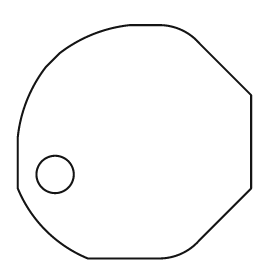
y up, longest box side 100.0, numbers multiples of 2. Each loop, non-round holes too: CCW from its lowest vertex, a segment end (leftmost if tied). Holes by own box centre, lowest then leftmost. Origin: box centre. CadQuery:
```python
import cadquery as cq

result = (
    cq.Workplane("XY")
    .moveTo(-20.0, -50.0)
    .lineTo(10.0, -50.0)
    .threePointArc((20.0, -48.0), (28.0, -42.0))
    .lineTo(50.0, -20.0)
    .lineTo(50.0, 20.0)
    .lineTo(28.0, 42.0)
    .threePointArc((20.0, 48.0), (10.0, 50.0))
    .lineTo(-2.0, 50.0)
    .threePointArc((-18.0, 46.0), (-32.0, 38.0))
    .lineTo(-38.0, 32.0)
    .threePointArc((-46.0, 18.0), (-50.0, 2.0))
    .lineTo(-50.0, -20.0)
    .threePointArc((-38.0, -38.0), (-20.0, -50.0))
    .close()
    .moveTo(-34.0, -14.0)
    .circle(8.0)
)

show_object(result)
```